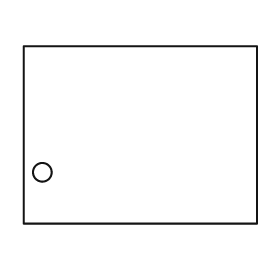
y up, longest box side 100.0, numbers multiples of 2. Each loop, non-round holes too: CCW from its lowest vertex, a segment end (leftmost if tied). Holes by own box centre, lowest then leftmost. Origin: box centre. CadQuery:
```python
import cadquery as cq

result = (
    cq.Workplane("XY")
    .moveTo(-50.0, -38.0)
    .lineTo(50.0, -38.0)
    .lineTo(50.0, 38.0)
    .lineTo(-50.0, 38.0)
    .close()
    .moveTo(-42.0, -16.0)
    .circle(4.0)
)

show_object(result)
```